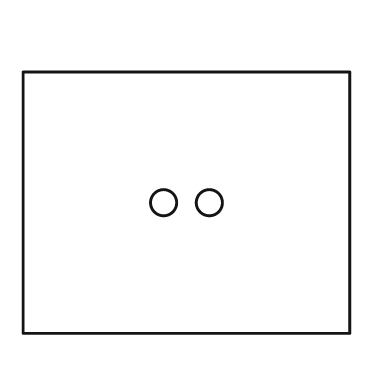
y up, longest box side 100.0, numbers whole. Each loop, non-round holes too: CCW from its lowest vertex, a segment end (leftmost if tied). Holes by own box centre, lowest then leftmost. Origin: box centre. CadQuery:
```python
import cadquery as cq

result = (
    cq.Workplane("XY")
    .moveTo(-50.0, -40.0)
    .lineTo(50.0, -40.0)
    .lineTo(50.0, 40.0)
    .lineTo(-50.0, 40.0)
    .close()
    .moveTo(-7.0, 0.0)
    .circle(4.0)
    .moveTo(7.0, 0.0)
    .circle(4.0)
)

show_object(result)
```